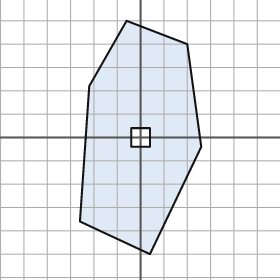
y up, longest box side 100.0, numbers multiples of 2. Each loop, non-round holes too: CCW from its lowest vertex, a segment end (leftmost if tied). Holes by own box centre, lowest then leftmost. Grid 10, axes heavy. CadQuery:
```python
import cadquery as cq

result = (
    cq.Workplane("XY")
    .moveTo(4.0, -50.0)
    .lineTo(26.0, -4.0)
    .lineTo(20.0, 40.0)
    .lineTo(-6.0, 50.0)
    .lineTo(-22.0, 22.0)
    .lineTo(-26.0, -36.0)
    .close()
    .moveTo(-4.0, -4.0)
    .lineTo(4.0, -4.0)
    .lineTo(4.0, 4.0)
    .lineTo(-4.0, 4.0)
    .close()
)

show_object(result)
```